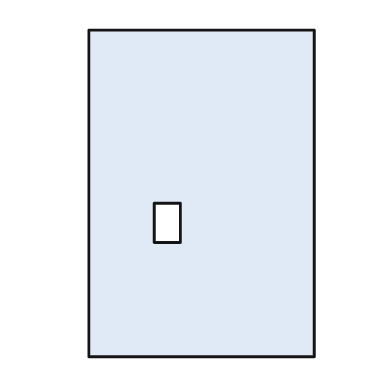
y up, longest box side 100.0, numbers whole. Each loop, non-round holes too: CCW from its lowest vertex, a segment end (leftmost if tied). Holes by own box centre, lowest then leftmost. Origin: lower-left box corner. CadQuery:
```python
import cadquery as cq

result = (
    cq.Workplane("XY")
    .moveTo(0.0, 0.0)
    .lineTo(69.0, 0.0)
    .lineTo(69.0, 100.0)
    .lineTo(0.0, 100.0)
    .close()
    .moveTo(20.0, 35.0)
    .lineTo(28.0, 35.0)
    .lineTo(28.0, 47.0)
    .lineTo(20.0, 47.0)
    .close()
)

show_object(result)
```